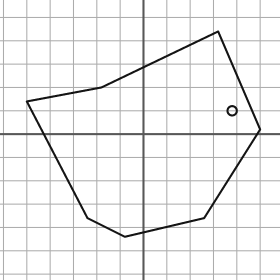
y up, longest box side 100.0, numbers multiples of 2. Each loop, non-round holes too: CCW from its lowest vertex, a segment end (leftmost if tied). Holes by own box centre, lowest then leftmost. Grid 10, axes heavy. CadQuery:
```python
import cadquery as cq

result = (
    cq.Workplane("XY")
    .moveTo(-8.0, -44.0)
    .lineTo(26.0, -36.0)
    .lineTo(50.0, 2.0)
    .lineTo(32.0, 44.0)
    .lineTo(-18.0, 20.0)
    .lineTo(-50.0, 14.0)
    .lineTo(-24.0, -36.0)
    .close()
    .moveTo(38.0, 10.0)
    .circle(2.0)
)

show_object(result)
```